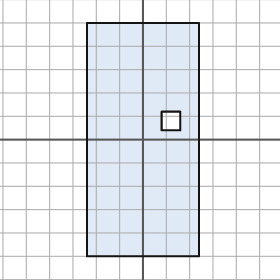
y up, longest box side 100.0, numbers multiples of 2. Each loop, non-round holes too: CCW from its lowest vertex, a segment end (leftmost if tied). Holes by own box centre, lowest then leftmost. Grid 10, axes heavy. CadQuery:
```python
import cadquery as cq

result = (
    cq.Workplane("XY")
    .moveTo(-24.0, -50.0)
    .lineTo(24.0, -50.0)
    .lineTo(24.0, 50.0)
    .lineTo(-24.0, 50.0)
    .close()
    .moveTo(8.0, 4.0)
    .lineTo(16.0, 4.0)
    .lineTo(16.0, 12.0)
    .lineTo(8.0, 12.0)
    .close()
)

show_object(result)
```